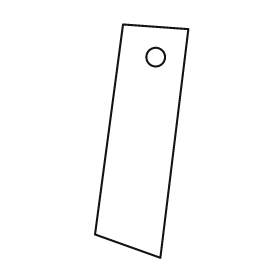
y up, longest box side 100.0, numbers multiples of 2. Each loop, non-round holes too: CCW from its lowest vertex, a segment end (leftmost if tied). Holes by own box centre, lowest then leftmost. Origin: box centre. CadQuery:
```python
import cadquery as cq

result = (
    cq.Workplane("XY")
    .moveTo(8.0, -50.0)
    .lineTo(20.0, 48.0)
    .lineTo(-8.0, 50.0)
    .lineTo(-20.0, -40.0)
    .close()
    .moveTo(6.0, 36.0)
    .circle(4.0)
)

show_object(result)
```